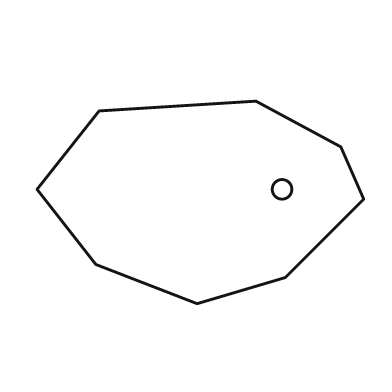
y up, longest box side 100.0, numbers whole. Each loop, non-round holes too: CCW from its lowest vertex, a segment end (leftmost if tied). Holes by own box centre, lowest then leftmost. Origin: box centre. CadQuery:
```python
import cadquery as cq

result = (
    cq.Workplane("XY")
    .moveTo(-1.0, -31.0)
    .lineTo(26.0, -23.0)
    .lineTo(50.0, 1.0)
    .lineTo(43.0, 17.0)
    .lineTo(17.0, 31.0)
    .lineTo(-31.0, 28.0)
    .lineTo(-50.0, 4.0)
    .lineTo(-32.0, -19.0)
    .close()
    .moveTo(25.0, 4.0)
    .circle(3.0)
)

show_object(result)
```